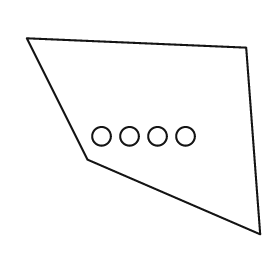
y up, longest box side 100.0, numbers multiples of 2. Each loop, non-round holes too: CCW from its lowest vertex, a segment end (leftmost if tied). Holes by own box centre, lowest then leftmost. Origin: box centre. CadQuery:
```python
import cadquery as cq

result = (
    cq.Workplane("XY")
    .moveTo(50.0, -42.0)
    .lineTo(44.0, 38.0)
    .lineTo(-50.0, 42.0)
    .lineTo(-24.0, -10.0)
    .close()
    .moveTo(-18.0, 0.0)
    .circle(4.0)
    .moveTo(-6.0, 0.0)
    .circle(4.0)
    .moveTo(6.0, 0.0)
    .circle(4.0)
    .moveTo(18.0, 0.0)
    .circle(4.0)
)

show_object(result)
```